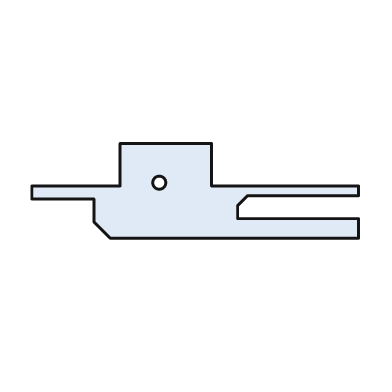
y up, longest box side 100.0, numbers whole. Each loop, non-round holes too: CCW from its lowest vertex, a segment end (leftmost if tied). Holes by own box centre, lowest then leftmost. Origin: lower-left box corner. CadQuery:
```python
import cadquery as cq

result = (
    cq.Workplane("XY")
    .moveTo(24.0, 0.0)
    .lineTo(100.0, 0.0)
    .lineTo(100.0, 6.0)
    .lineTo(63.0, 6.0)
    .lineTo(63.0, 10.0)
    .lineTo(66.0, 13.0)
    .lineTo(100.0, 13.0)
    .lineTo(100.0, 16.0)
    .lineTo(55.0, 16.0)
    .lineTo(55.0, 29.0)
    .lineTo(27.0, 29.0)
    .lineTo(27.0, 16.0)
    .lineTo(0.0, 16.0)
    .lineTo(0.0, 12.0)
    .lineTo(19.0, 12.0)
    .lineTo(19.0, 5.0)
    .close()
    .moveTo(39.0, 17.0)
    .circle(2.0)
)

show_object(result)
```